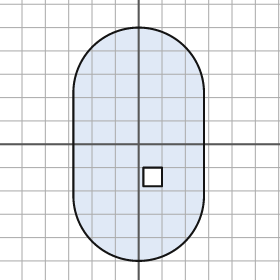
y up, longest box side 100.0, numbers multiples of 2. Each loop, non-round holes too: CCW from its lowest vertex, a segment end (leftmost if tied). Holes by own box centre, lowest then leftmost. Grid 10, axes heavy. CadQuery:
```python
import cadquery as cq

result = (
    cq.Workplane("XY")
    .moveTo(-28.0, -22.0)
    .threePointArc((0.0, -50.0), (28.0, -22.0))
    .lineTo(28.0, 22.0)
    .threePointArc((0.0, 50.0), (-28.0, 22.0))
    .close()
    .moveTo(2.0, -18.0)
    .lineTo(10.0, -18.0)
    .lineTo(10.0, -10.0)
    .lineTo(2.0, -10.0)
    .close()
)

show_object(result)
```